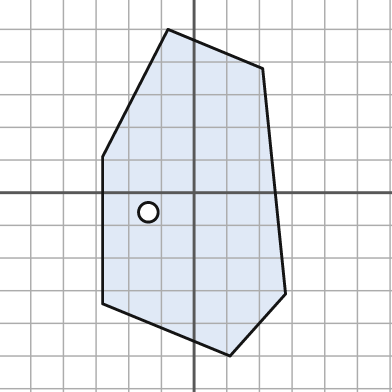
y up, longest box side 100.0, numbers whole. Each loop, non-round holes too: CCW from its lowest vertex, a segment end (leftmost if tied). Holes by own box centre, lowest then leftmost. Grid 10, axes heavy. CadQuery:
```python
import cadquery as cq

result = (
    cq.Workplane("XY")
    .moveTo(11.0, -50.0)
    .lineTo(28.0, -31.0)
    .lineTo(21.0, 38.0)
    .lineTo(-8.0, 50.0)
    .lineTo(-28.0, 11.0)
    .lineTo(-28.0, -34.0)
    .close()
    .moveTo(-14.0, -6.0)
    .circle(3.0)
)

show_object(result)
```